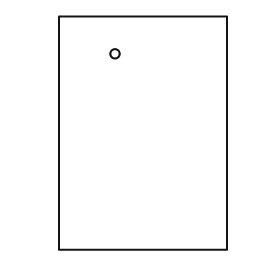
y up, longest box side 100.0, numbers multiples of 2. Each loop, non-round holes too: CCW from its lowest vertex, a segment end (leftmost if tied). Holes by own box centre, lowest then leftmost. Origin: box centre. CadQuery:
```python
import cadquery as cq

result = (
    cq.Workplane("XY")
    .moveTo(-36.0, -50.0)
    .lineTo(36.0, -50.0)
    .lineTo(36.0, 50.0)
    .lineTo(-36.0, 50.0)
    .close()
    .moveTo(-12.0, 34.0)
    .circle(2.0)
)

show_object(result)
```